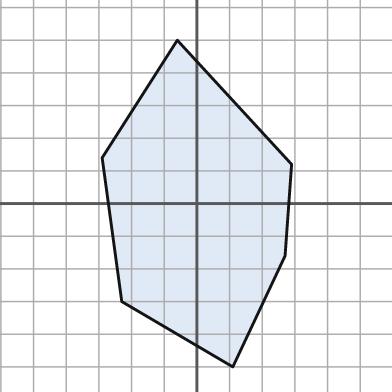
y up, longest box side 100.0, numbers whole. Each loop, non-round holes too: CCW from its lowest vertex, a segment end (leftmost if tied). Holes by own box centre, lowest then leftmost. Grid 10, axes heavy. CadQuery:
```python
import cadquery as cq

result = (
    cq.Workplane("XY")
    .moveTo(11.0, -50.0)
    .lineTo(27.0, -16.0)
    .lineTo(29.0, 12.0)
    .lineTo(-6.0, 50.0)
    .lineTo(-29.0, 14.0)
    .lineTo(-23.0, -30.0)
    .close()
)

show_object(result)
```